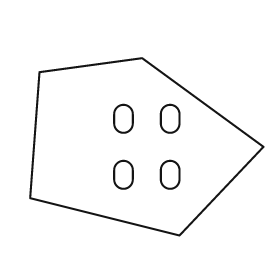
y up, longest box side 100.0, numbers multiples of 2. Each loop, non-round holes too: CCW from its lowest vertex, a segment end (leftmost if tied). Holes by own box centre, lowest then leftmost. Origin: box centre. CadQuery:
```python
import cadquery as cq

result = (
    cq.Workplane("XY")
    .moveTo(14.0, -38.0)
    .lineTo(50.0, 0.0)
    .lineTo(-2.0, 38.0)
    .lineTo(-46.0, 32.0)
    .lineTo(-50.0, -22.0)
    .close()
    .moveTo(-14.0, -14.0)
    .threePointArc((-10.0, -18.0), (-6.0, -14.0))
    .lineTo(-6.0, -10.0)
    .threePointArc((-10.0, -6.0), (-14.0, -10.0))
    .close()
    .moveTo(6.0, -14.0)
    .threePointArc((10.0, -18.0), (14.0, -14.0))
    .lineTo(14.0, -10.0)
    .threePointArc((10.0, -6.0), (6.0, -10.0))
    .close()
    .moveTo(-14.0, 10.0)
    .threePointArc((-10.0, 6.0), (-6.0, 10.0))
    .lineTo(-6.0, 14.0)
    .threePointArc((-10.0, 18.0), (-14.0, 14.0))
    .close()
    .moveTo(6.0, 10.0)
    .threePointArc((10.0, 6.0), (14.0, 10.0))
    .lineTo(14.0, 14.0)
    .threePointArc((10.0, 18.0), (6.0, 14.0))
    .close()
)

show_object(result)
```